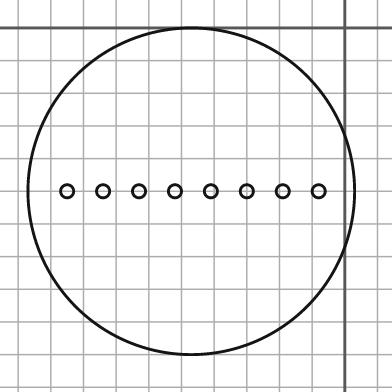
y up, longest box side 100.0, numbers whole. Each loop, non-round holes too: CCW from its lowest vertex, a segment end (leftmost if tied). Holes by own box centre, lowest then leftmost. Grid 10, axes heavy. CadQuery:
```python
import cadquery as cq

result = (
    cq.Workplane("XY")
    .moveTo(-47.0, -50.0)
    .circle(50.0)
    .moveTo(-85.0, -50.0)
    .circle(2.0)
    .moveTo(-74.0, -50.0)
    .circle(2.0)
    .moveTo(-63.0, -50.0)
    .circle(2.0)
    .moveTo(-52.0, -50.0)
    .circle(2.0)
    .moveTo(-41.0, -50.0)
    .circle(2.0)
    .moveTo(-30.0, -50.0)
    .circle(2.0)
    .moveTo(-19.0, -50.0)
    .circle(2.0)
    .moveTo(-8.0, -50.0)
    .circle(2.0)
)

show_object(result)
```